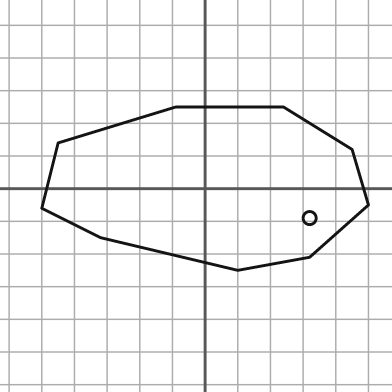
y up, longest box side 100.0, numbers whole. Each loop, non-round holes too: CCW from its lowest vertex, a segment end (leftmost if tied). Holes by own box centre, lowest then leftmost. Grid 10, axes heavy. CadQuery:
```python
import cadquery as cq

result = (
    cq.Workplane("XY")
    .moveTo(10.0, -25.0)
    .lineTo(32.0, -21.0)
    .lineTo(50.0, -5.0)
    .lineTo(45.0, 12.0)
    .lineTo(24.0, 25.0)
    .lineTo(-9.0, 25.0)
    .lineTo(-45.0, 14.0)
    .lineTo(-50.0, -6.0)
    .lineTo(-32.0, -15.0)
    .close()
    .moveTo(32.0, -9.0)
    .circle(2.0)
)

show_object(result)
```